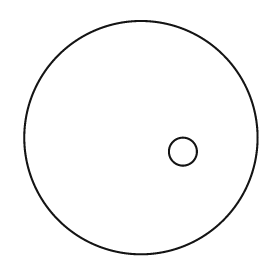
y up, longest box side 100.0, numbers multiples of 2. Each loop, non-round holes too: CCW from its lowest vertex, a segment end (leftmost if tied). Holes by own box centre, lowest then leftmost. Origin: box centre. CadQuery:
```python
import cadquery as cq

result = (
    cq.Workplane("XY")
    .moveTo(0.0, 0.0)
    .circle(50.0)
    .moveTo(18.0, -6.0)
    .circle(6.0)
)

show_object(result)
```